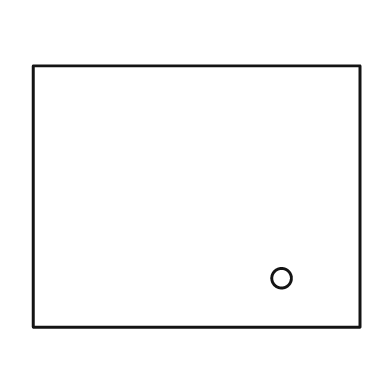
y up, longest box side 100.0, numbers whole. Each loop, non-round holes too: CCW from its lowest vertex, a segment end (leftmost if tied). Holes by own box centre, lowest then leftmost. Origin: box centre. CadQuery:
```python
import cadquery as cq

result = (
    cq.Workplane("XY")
    .moveTo(-50.0, -40.0)
    .lineTo(50.0, -40.0)
    .lineTo(50.0, 40.0)
    .lineTo(-50.0, 40.0)
    .close()
    .moveTo(26.0, -25.0)
    .circle(3.0)
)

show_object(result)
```